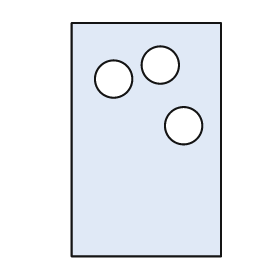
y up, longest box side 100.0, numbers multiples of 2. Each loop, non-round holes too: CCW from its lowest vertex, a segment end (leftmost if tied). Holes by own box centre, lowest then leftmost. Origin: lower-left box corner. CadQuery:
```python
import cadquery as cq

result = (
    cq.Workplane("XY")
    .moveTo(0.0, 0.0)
    .lineTo(64.0, 0.0)
    .lineTo(64.0, 100.0)
    .lineTo(0.0, 100.0)
    .close()
    .moveTo(48.0, 56.0)
    .circle(8.0)
    .moveTo(18.0, 76.0)
    .circle(8.0)
    .moveTo(38.0, 82.0)
    .circle(8.0)
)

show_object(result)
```